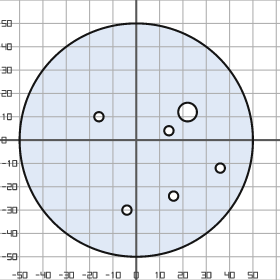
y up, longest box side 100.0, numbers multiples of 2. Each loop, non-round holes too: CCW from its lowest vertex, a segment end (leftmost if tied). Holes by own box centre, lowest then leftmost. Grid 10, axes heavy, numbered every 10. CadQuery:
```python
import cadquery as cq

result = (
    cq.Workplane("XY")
    .moveTo(0.0, 0.0)
    .circle(50.0)
    .moveTo(-4.0, -30.0)
    .circle(2.0)
    .moveTo(16.0, -24.0)
    .circle(2.0)
    .moveTo(36.0, -12.0)
    .circle(2.0)
    .moveTo(14.0, 4.0)
    .circle(2.0)
    .moveTo(-16.0, 10.0)
    .circle(2.0)
    .moveTo(22.0, 12.0)
    .circle(4.0)
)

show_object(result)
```